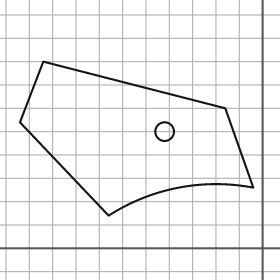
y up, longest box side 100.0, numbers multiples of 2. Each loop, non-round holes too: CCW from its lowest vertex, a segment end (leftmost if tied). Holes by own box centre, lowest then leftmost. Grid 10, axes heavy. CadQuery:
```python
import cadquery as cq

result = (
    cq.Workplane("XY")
    .moveTo(-66.0, 14.0)
    .threePointArc((-36.0, 26.0), (-4.0, 26.0))
    .lineTo(-16.0, 60.0)
    .lineTo(-94.0, 80.0)
    .lineTo(-104.0, 54.0)
    .close()
    .moveTo(-42.0, 50.0)
    .circle(4.0)
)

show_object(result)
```